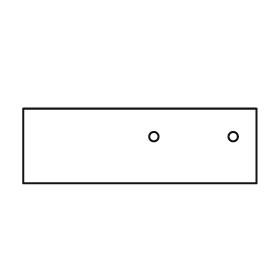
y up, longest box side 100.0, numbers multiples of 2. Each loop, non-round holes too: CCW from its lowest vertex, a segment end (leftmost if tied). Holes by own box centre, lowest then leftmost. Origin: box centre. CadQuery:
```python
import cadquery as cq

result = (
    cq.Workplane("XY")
    .moveTo(-50.0, -16.0)
    .lineTo(50.0, -16.0)
    .lineTo(50.0, 16.0)
    .lineTo(-50.0, 16.0)
    .close()
    .moveTo(6.0, 4.0)
    .circle(2.0)
    .moveTo(40.0, 4.0)
    .circle(2.0)
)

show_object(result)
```